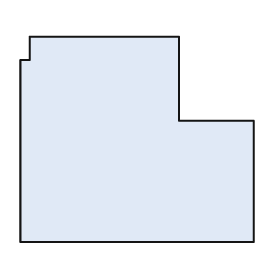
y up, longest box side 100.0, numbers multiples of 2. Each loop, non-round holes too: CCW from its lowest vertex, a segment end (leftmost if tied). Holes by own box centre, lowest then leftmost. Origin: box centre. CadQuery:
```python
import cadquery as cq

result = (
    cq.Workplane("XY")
    .moveTo(-50.0, -44.0)
    .lineTo(50.0, -44.0)
    .lineTo(50.0, 8.0)
    .lineTo(18.0, 8.0)
    .lineTo(18.0, 44.0)
    .lineTo(-46.0, 44.0)
    .lineTo(-46.0, 34.0)
    .lineTo(-50.0, 34.0)
    .close()
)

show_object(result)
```